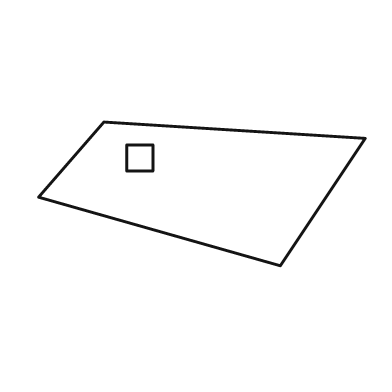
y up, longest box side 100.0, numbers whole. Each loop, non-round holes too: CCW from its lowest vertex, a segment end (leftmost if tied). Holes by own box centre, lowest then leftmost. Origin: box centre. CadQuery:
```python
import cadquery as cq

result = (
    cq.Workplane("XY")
    .moveTo(24.0, -22.0)
    .lineTo(50.0, 17.0)
    .lineTo(-30.0, 22.0)
    .lineTo(-50.0, -1.0)
    .close()
    .moveTo(-23.0, 7.0)
    .lineTo(-15.0, 7.0)
    .lineTo(-15.0, 15.0)
    .lineTo(-23.0, 15.0)
    .close()
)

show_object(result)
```